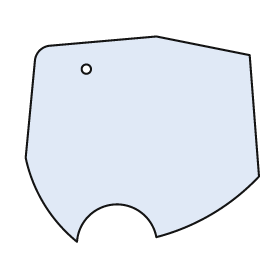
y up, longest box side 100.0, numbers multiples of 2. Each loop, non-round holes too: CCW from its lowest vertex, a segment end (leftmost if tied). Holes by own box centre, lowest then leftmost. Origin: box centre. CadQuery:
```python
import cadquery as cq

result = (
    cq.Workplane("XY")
    .moveTo(-28.0, -44.0)
    .threePointArc((-12.0, -28.0), (6.0, -42.0))
    .threePointArc((30.0, -32.0), (50.0, -16.0))
    .lineTo(46.0, 36.0)
    .lineTo(6.0, 44.0)
    .lineTo(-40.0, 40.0)
    .threePointArc((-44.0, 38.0), (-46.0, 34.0))
    .lineTo(-50.0, -8.0)
    .threePointArc((-42.0, -28.0), (-28.0, -44.0))
    .close()
    .moveTo(-24.0, 30.0)
    .circle(2.0)
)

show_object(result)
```